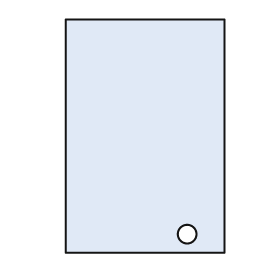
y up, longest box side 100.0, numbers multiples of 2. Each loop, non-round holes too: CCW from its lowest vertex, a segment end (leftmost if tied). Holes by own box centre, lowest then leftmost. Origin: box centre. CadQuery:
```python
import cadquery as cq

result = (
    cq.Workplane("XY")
    .moveTo(-34.0, -50.0)
    .lineTo(34.0, -50.0)
    .lineTo(34.0, 50.0)
    .lineTo(-34.0, 50.0)
    .close()
    .moveTo(18.0, -42.0)
    .circle(4.0)
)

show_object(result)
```